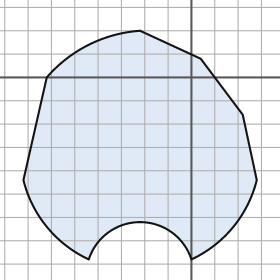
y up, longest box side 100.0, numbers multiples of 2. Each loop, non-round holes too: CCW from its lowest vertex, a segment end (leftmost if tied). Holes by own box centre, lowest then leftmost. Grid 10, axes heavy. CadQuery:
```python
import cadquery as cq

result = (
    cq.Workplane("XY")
    .moveTo(-44.0, -78.0)
    .threePointArc((-22.0, -62.0), (0.0, -78.0))
    .threePointArc((18.0, -64.0), (28.0, -44.0))
    .lineTo(22.0, -16.0)
    .lineTo(4.0, 8.0)
    .lineTo(-22.0, 20.0)
    .threePointArc((-44.0, 14.0), (-62.0, 0.0))
    .lineTo(-72.0, -44.0)
    .threePointArc((-62.0, -64.0), (-44.0, -78.0))
    .close()
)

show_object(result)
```